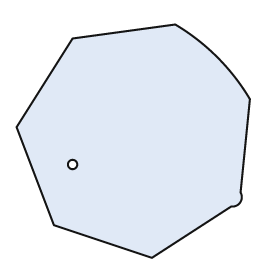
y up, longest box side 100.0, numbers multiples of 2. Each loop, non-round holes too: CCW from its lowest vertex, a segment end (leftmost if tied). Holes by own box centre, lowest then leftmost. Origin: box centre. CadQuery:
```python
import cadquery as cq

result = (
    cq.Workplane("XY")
    .moveTo(8.0, -50.0)
    .lineTo(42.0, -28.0)
    .threePointArc((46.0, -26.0), (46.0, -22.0))
    .lineTo(50.0, 18.0)
    .threePointArc((36.0, 36.0), (18.0, 50.0))
    .lineTo(-26.0, 44.0)
    .lineTo(-50.0, 6.0)
    .lineTo(-34.0, -36.0)
    .close()
    .moveTo(-26.0, -10.0)
    .circle(2.0)
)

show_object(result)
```